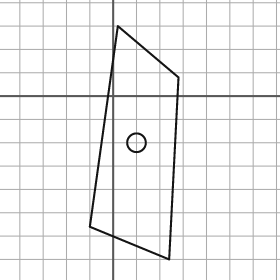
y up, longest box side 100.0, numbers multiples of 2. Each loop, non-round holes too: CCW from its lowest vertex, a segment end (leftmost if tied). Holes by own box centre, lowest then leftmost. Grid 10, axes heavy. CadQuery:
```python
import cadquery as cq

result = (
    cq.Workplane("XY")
    .moveTo(24.0, -70.0)
    .lineTo(28.0, 8.0)
    .lineTo(2.0, 30.0)
    .lineTo(-10.0, -56.0)
    .close()
    .moveTo(10.0, -20.0)
    .circle(4.0)
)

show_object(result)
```